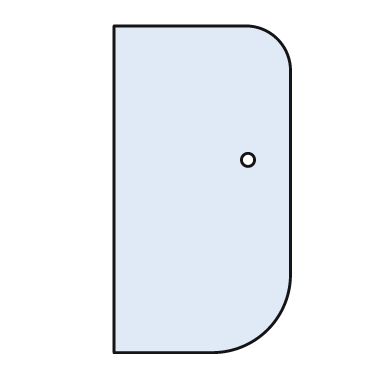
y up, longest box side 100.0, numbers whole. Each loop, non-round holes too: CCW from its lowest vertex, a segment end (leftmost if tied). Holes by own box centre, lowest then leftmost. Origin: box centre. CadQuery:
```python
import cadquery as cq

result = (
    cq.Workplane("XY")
    .moveTo(-27.0, -50.0)
    .lineTo(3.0, -50.0)
    .threePointArc((20.0, -43.0), (27.0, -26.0))
    .lineTo(27.0, 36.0)
    .threePointArc((23.0, 46.0), (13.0, 50.0))
    .lineTo(-27.0, 50.0)
    .close()
    .moveTo(14.0, 9.0)
    .circle(2.0)
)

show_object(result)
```